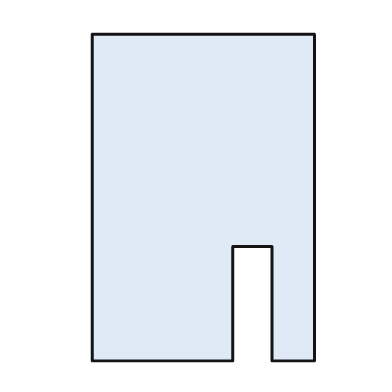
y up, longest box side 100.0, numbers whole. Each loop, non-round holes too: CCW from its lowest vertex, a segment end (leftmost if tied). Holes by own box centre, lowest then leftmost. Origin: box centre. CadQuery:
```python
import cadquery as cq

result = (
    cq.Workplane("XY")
    .moveTo(-34.0, -50.0)
    .lineTo(9.0, -50.0)
    .lineTo(9.0, -15.0)
    .lineTo(21.0, -15.0)
    .lineTo(21.0, -50.0)
    .lineTo(34.0, -50.0)
    .lineTo(34.0, 50.0)
    .lineTo(-34.0, 50.0)
    .close()
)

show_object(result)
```